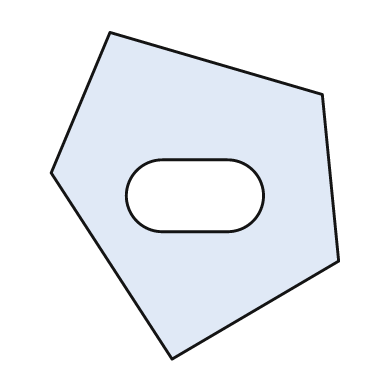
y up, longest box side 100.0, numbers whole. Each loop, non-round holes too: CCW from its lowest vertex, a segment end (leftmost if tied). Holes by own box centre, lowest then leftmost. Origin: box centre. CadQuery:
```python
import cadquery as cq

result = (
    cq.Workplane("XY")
    .moveTo(-7.0, -50.0)
    .lineTo(44.0, -20.0)
    .lineTo(39.0, 31.0)
    .lineTo(-26.0, 50.0)
    .lineTo(-44.0, 7.0)
    .close()
    .moveTo(-10.0, -11.0)
    .lineTo(10.0, -11.0)
    .threePointArc((21.0, 0.0), (10.0, 11.0))
    .lineTo(-10.0, 11.0)
    .threePointArc((-21.0, 0.0), (-10.0, -11.0))
    .close()
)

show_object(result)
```